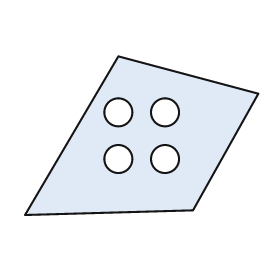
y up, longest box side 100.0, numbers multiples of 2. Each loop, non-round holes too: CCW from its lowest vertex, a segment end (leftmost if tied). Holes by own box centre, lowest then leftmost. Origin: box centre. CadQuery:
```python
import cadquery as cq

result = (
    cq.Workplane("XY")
    .moveTo(-50.0, -34.0)
    .lineTo(22.0, -32.0)
    .lineTo(50.0, 18.0)
    .lineTo(-10.0, 34.0)
    .close()
    .moveTo(-10.0, -10.0)
    .circle(6.0)
    .moveTo(10.0, -10.0)
    .circle(6.0)
    .moveTo(-10.0, 10.0)
    .circle(6.0)
    .moveTo(10.0, 10.0)
    .circle(6.0)
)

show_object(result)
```